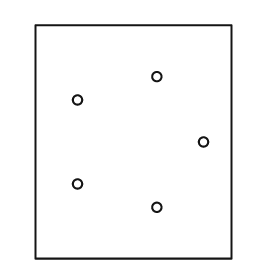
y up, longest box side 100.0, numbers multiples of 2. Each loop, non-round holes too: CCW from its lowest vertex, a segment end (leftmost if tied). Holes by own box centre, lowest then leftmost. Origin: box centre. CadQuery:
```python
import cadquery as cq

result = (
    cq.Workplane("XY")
    .moveTo(-42.0, -50.0)
    .lineTo(42.0, -50.0)
    .lineTo(42.0, 50.0)
    .lineTo(-42.0, 50.0)
    .close()
    .moveTo(10.0, -28.0)
    .circle(2.0)
    .moveTo(-24.0, -18.0)
    .circle(2.0)
    .moveTo(30.0, 0.0)
    .circle(2.0)
    .moveTo(-24.0, 18.0)
    .circle(2.0)
    .moveTo(10.0, 28.0)
    .circle(2.0)
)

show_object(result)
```